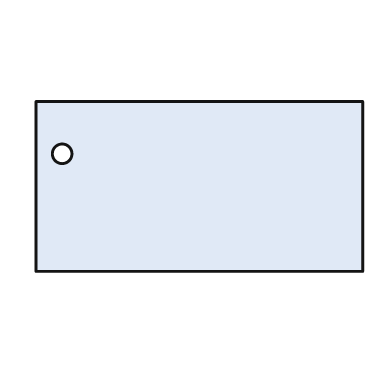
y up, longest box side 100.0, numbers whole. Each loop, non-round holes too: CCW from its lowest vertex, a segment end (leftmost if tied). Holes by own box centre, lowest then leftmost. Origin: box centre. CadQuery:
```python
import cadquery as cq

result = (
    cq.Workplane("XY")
    .moveTo(-50.0, -26.0)
    .lineTo(50.0, -26.0)
    .lineTo(50.0, 26.0)
    .lineTo(-50.0, 26.0)
    .close()
    .moveTo(-42.0, 10.0)
    .circle(3.0)
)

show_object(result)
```